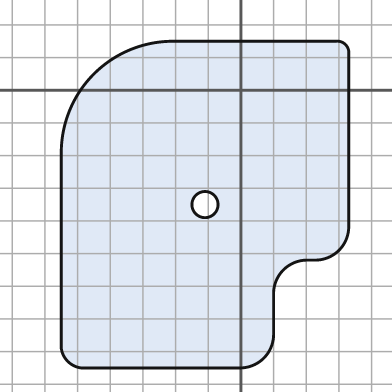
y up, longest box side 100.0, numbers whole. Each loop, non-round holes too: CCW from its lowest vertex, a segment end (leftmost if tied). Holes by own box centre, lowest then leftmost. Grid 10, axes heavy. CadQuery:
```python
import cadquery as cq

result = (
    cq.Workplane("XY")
    .moveTo(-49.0, -85.0)
    .lineTo(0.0, -85.0)
    .threePointArc((7.0, -82.0), (10.0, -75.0))
    .lineTo(10.0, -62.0)
    .threePointArc((13.0, -55.0), (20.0, -52.0))
    .lineTo(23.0, -52.0)
    .threePointArc((30.0, -49.0), (33.0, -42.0))
    .lineTo(33.0, 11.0)
    .threePointArc((32.0, 14.0), (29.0, 15.0))
    .lineTo(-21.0, 15.0)
    .threePointArc((-45.0, 5.0), (-55.0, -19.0))
    .lineTo(-55.0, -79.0)
    .threePointArc((-53.0, -83.0), (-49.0, -85.0))
    .close()
    .moveTo(-11.0, -35.0)
    .circle(4.0)
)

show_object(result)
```